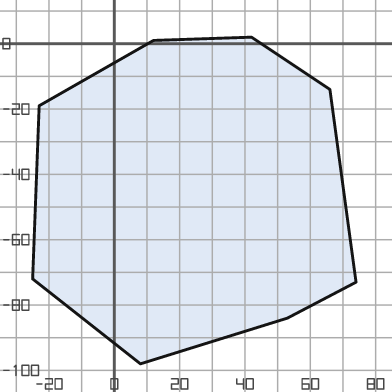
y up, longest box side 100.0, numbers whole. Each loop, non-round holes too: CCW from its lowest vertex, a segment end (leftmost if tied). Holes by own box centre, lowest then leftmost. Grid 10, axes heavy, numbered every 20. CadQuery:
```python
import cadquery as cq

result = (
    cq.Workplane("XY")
    .moveTo(8.0, -98.0)
    .lineTo(53.0, -84.0)
    .lineTo(74.0, -73.0)
    .lineTo(66.0, -14.0)
    .lineTo(42.0, 2.0)
    .lineTo(12.0, 1.0)
    .lineTo(-23.0, -19.0)
    .lineTo(-25.0, -72.0)
    .close()
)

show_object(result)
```